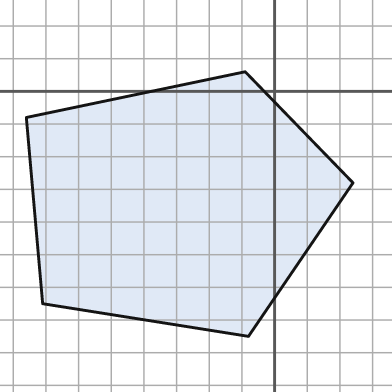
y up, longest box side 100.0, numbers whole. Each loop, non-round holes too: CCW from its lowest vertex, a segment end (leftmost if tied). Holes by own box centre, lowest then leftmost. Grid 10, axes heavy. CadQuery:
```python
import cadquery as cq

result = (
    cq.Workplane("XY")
    .moveTo(-8.0, -75.0)
    .lineTo(24.0, -28.0)
    .lineTo(-9.0, 6.0)
    .lineTo(-76.0, -8.0)
    .lineTo(-71.0, -65.0)
    .close()
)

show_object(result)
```